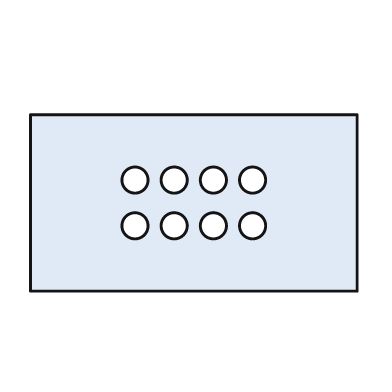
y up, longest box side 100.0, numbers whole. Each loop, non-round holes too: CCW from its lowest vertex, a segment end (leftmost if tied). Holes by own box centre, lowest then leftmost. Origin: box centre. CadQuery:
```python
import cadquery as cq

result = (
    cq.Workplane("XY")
    .moveTo(-50.0, -27.0)
    .lineTo(50.0, -27.0)
    .lineTo(50.0, 27.0)
    .lineTo(-50.0, 27.0)
    .close()
    .moveTo(-18.0, -7.0)
    .circle(4.0)
    .moveTo(-6.0, -7.0)
    .circle(4.0)
    .moveTo(6.0, -7.0)
    .circle(4.0)
    .moveTo(18.0, -7.0)
    .circle(4.0)
    .moveTo(-18.0, 7.0)
    .circle(4.0)
    .moveTo(-6.0, 7.0)
    .circle(4.0)
    .moveTo(6.0, 7.0)
    .circle(4.0)
    .moveTo(18.0, 7.0)
    .circle(4.0)
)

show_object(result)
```